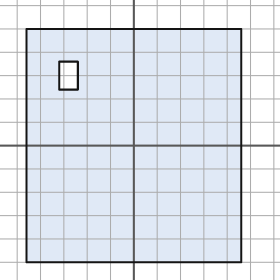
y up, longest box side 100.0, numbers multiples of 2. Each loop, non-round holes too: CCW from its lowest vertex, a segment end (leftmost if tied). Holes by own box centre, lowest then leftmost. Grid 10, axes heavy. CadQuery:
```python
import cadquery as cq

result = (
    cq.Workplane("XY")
    .moveTo(-46.0, -50.0)
    .lineTo(46.0, -50.0)
    .lineTo(46.0, 50.0)
    .lineTo(-46.0, 50.0)
    .close()
    .moveTo(-32.0, 24.0)
    .lineTo(-24.0, 24.0)
    .lineTo(-24.0, 36.0)
    .lineTo(-32.0, 36.0)
    .close()
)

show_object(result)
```